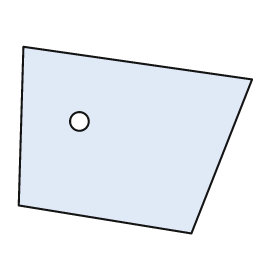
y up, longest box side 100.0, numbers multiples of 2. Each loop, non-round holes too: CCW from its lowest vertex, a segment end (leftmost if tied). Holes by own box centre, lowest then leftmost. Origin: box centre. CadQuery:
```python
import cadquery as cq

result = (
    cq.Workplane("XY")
    .moveTo(24.0, -40.0)
    .lineTo(50.0, 26.0)
    .lineTo(-48.0, 40.0)
    .lineTo(-50.0, -28.0)
    .close()
    .moveTo(-24.0, 8.0)
    .circle(4.0)
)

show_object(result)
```